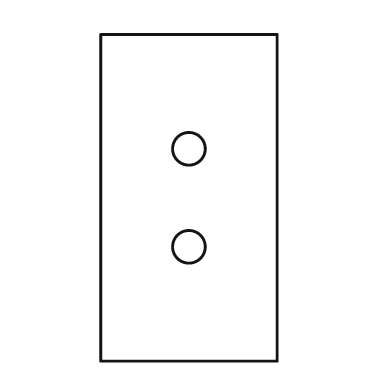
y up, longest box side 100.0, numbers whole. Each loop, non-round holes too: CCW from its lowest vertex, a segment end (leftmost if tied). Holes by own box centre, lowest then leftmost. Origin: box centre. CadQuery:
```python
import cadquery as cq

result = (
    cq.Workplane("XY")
    .moveTo(-27.0, -50.0)
    .lineTo(27.0, -50.0)
    .lineTo(27.0, 50.0)
    .lineTo(-27.0, 50.0)
    .close()
    .moveTo(0.0, -15.0)
    .circle(5.0)
    .moveTo(0.0, 15.0)
    .circle(5.0)
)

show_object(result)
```